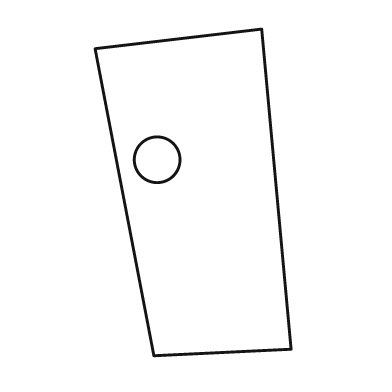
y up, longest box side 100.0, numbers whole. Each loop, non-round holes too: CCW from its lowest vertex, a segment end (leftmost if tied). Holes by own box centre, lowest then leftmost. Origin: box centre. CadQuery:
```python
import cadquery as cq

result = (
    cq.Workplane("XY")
    .moveTo(-12.0, -50.0)
    .lineTo(30.0, -48.0)
    .lineTo(21.0, 50.0)
    .lineTo(-30.0, 44.0)
    .close()
    .moveTo(-11.0, 10.0)
    .circle(7.0)
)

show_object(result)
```